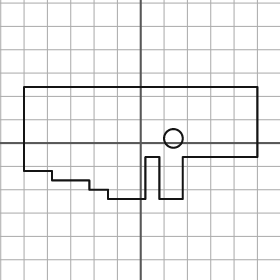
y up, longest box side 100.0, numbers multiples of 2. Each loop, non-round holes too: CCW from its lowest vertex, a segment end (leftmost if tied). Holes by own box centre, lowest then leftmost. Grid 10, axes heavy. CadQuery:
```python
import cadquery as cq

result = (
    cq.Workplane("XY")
    .moveTo(-14.0, -24.0)
    .lineTo(2.0, -24.0)
    .lineTo(2.0, -6.0)
    .lineTo(8.0, -6.0)
    .lineTo(8.0, -24.0)
    .lineTo(18.0, -24.0)
    .lineTo(18.0, -6.0)
    .lineTo(50.0, -6.0)
    .lineTo(50.0, 24.0)
    .lineTo(-50.0, 24.0)
    .lineTo(-50.0, -12.0)
    .lineTo(-38.0, -12.0)
    .lineTo(-38.0, -16.0)
    .lineTo(-22.0, -16.0)
    .lineTo(-22.0, -20.0)
    .lineTo(-14.0, -20.0)
    .close()
    .moveTo(14.0, 2.0)
    .circle(4.0)
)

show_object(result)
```